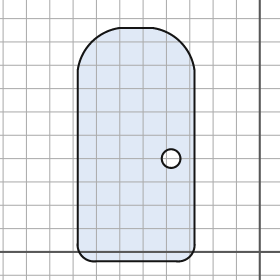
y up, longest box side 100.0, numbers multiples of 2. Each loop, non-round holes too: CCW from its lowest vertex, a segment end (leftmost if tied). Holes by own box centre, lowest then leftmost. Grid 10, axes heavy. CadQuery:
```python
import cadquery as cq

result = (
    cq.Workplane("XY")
    .moveTo(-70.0, -4.0)
    .lineTo(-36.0, -4.0)
    .threePointArc((-30.0, -2.0), (-28.0, 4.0))
    .lineTo(-28.0, 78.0)
    .threePointArc((-34.0, 90.0), (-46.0, 96.0))
    .lineTo(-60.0, 96.0)
    .threePointArc((-72.0, 90.0), (-78.0, 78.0))
    .lineTo(-78.0, 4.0)
    .threePointArc((-76.0, -2.0), (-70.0, -4.0))
    .close()
    .moveTo(-38.0, 40.0)
    .circle(4.0)
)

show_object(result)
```